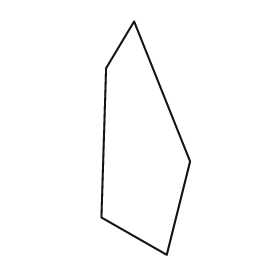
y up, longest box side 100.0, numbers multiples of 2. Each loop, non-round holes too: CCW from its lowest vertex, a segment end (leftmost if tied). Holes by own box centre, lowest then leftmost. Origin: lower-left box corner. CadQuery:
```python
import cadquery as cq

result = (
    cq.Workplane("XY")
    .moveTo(28.0, 0.0)
    .lineTo(38.0, 40.0)
    .lineTo(14.0, 100.0)
    .lineTo(2.0, 80.0)
    .lineTo(0.0, 16.0)
    .close()
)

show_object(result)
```